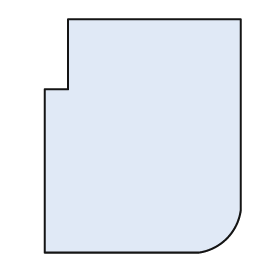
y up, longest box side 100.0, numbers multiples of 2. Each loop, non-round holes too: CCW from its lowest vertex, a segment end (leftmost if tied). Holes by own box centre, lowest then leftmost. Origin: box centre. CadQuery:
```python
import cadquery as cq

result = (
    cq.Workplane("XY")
    .moveTo(-42.0, -50.0)
    .lineTo(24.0, -50.0)
    .threePointArc((36.0, -44.0), (42.0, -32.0))
    .lineTo(42.0, 50.0)
    .lineTo(-32.0, 50.0)
    .lineTo(-32.0, 20.0)
    .lineTo(-42.0, 20.0)
    .close()
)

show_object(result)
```